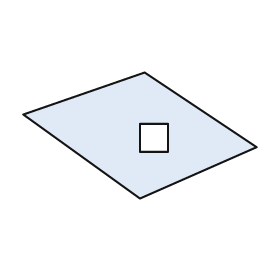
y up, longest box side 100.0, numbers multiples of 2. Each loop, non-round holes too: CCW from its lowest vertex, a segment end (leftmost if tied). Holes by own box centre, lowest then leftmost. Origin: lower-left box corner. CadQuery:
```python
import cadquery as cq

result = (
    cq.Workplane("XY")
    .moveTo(50.0, 0.0)
    .lineTo(100.0, 22.0)
    .lineTo(52.0, 54.0)
    .lineTo(0.0, 36.0)
    .close()
    .moveTo(50.0, 20.0)
    .lineTo(62.0, 20.0)
    .lineTo(62.0, 32.0)
    .lineTo(50.0, 32.0)
    .close()
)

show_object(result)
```